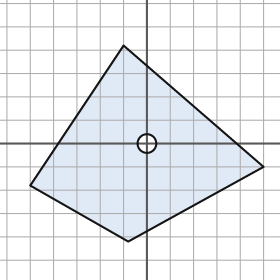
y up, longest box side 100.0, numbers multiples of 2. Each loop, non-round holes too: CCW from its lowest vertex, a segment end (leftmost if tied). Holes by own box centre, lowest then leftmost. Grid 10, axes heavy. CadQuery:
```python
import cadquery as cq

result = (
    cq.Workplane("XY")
    .moveTo(-8.0, -42.0)
    .lineTo(50.0, -10.0)
    .lineTo(-10.0, 42.0)
    .lineTo(-50.0, -18.0)
    .close()
    .moveTo(0.0, 0.0)
    .circle(4.0)
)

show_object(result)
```